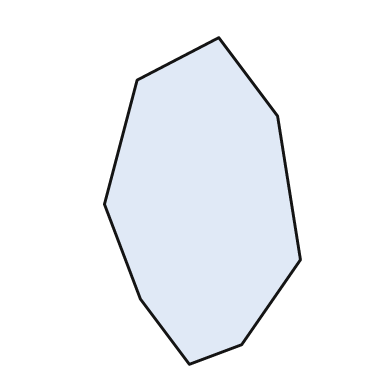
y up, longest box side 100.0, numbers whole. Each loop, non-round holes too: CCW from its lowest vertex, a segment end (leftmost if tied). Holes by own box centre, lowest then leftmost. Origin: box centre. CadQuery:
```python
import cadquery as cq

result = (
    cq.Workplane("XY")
    .moveTo(-4.0, -50.0)
    .lineTo(12.0, -44.0)
    .lineTo(30.0, -18.0)
    .lineTo(23.0, 26.0)
    .lineTo(5.0, 50.0)
    .lineTo(-20.0, 37.0)
    .lineTo(-30.0, -1.0)
    .lineTo(-19.0, -30.0)
    .close()
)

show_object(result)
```